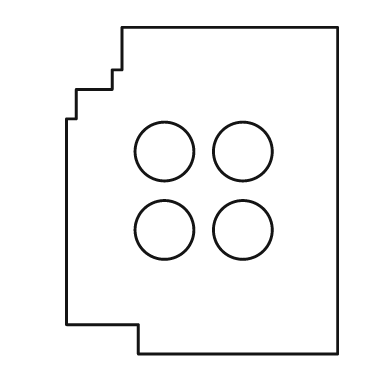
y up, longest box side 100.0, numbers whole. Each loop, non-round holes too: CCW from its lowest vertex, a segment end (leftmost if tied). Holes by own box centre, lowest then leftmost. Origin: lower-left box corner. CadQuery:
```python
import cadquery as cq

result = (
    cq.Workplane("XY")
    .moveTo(22.0, 0.0)
    .lineTo(83.0, 0.0)
    .lineTo(83.0, 100.0)
    .lineTo(17.0, 100.0)
    .lineTo(17.0, 87.0)
    .lineTo(14.0, 87.0)
    .lineTo(14.0, 81.0)
    .lineTo(3.0, 81.0)
    .lineTo(3.0, 72.0)
    .lineTo(0.0, 72.0)
    .lineTo(0.0, 9.0)
    .lineTo(22.0, 9.0)
    .close()
    .moveTo(30.0, 38.0)
    .circle(9.0)
    .moveTo(54.0, 38.0)
    .circle(9.0)
    .moveTo(30.0, 62.0)
    .circle(9.0)
    .moveTo(54.0, 62.0)
    .circle(9.0)
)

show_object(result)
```